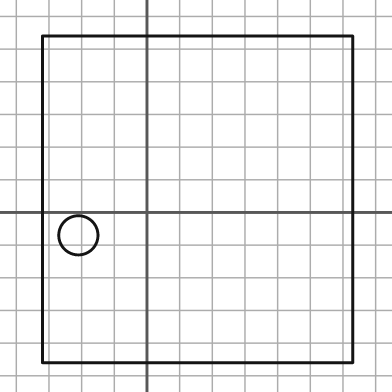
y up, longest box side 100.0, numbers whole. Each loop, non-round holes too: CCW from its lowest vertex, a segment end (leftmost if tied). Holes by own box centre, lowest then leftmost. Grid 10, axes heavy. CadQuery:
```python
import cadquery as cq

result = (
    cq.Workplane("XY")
    .moveTo(-32.0, -46.0)
    .lineTo(63.0, -46.0)
    .lineTo(63.0, 54.0)
    .lineTo(-32.0, 54.0)
    .close()
    .moveTo(-21.0, -7.0)
    .circle(6.0)
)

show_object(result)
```